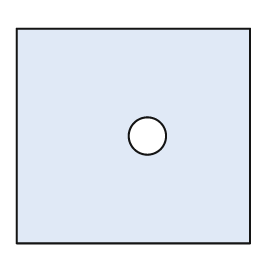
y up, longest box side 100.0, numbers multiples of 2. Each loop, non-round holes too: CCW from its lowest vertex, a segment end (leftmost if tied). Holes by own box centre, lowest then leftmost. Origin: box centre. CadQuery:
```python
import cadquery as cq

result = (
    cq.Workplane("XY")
    .moveTo(-50.0, -46.0)
    .lineTo(50.0, -46.0)
    .lineTo(50.0, 46.0)
    .lineTo(-50.0, 46.0)
    .close()
    .moveTo(6.0, 0.0)
    .circle(8.0)
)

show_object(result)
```